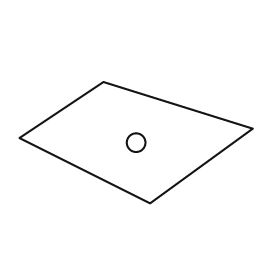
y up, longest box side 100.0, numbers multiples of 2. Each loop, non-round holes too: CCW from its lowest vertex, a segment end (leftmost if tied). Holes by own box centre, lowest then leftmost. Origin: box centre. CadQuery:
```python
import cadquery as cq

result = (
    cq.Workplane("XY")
    .moveTo(6.0, -26.0)
    .lineTo(50.0, 6.0)
    .lineTo(-14.0, 26.0)
    .lineTo(-50.0, 2.0)
    .close()
    .moveTo(0.0, 0.0)
    .circle(4.0)
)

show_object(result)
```